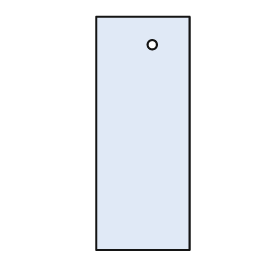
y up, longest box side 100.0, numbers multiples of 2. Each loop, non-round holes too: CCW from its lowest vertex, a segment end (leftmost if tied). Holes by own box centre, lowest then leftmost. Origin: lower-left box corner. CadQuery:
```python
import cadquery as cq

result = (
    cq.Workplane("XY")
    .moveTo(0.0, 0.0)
    .lineTo(40.0, 0.0)
    .lineTo(40.0, 100.0)
    .lineTo(0.0, 100.0)
    .close()
    .moveTo(24.0, 88.0)
    .circle(2.0)
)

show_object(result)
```